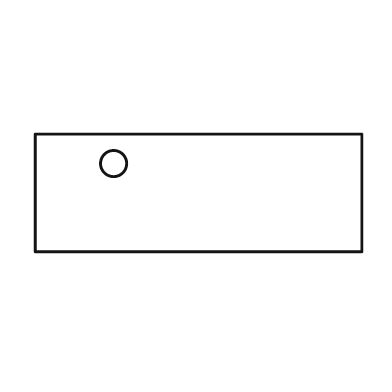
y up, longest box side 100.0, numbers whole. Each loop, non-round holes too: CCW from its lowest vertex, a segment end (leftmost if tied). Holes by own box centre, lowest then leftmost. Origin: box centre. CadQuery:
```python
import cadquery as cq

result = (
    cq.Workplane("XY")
    .moveTo(-50.0, -18.0)
    .lineTo(50.0, -18.0)
    .lineTo(50.0, 18.0)
    .lineTo(-50.0, 18.0)
    .close()
    .moveTo(-26.0, 9.0)
    .circle(4.0)
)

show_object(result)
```